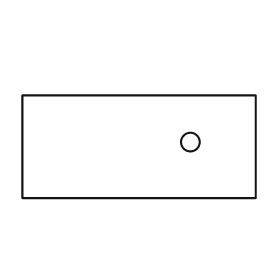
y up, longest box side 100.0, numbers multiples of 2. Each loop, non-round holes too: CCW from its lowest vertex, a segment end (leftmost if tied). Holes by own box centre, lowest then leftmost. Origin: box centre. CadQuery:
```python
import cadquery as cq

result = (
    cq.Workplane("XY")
    .moveTo(-50.0, -22.0)
    .lineTo(50.0, -22.0)
    .lineTo(50.0, 22.0)
    .lineTo(-50.0, 22.0)
    .close()
    .moveTo(22.0, 2.0)
    .circle(4.0)
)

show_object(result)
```